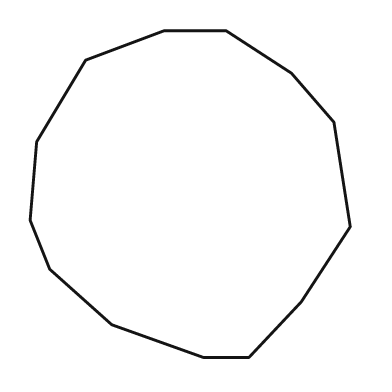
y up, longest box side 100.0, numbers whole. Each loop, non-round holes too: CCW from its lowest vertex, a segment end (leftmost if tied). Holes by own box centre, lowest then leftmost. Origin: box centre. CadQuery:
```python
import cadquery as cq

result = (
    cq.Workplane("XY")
    .moveTo(4.0, -50.0)
    .lineTo(18.0, -50.0)
    .lineTo(34.0, -33.0)
    .lineTo(49.0, -10.0)
    .lineTo(44.0, 22.0)
    .lineTo(31.0, 37.0)
    .lineTo(11.0, 50.0)
    .lineTo(-8.0, 50.0)
    .lineTo(-32.0, 41.0)
    .lineTo(-47.0, 16.0)
    .lineTo(-49.0, -8.0)
    .lineTo(-43.0, -23.0)
    .lineTo(-24.0, -40.0)
    .close()
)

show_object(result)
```